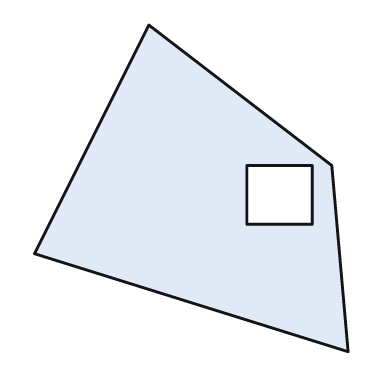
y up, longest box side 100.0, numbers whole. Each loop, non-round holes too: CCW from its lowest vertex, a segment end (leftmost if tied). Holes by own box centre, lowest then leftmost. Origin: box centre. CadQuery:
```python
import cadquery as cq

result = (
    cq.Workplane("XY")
    .moveTo(48.0, -50.0)
    .lineTo(43.0, 7.0)
    .lineTo(-13.0, 50.0)
    .lineTo(-48.0, -20.0)
    .close()
    .moveTo(17.0, -11.0)
    .lineTo(37.0, -11.0)
    .lineTo(37.0, 7.0)
    .lineTo(17.0, 7.0)
    .close()
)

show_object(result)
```